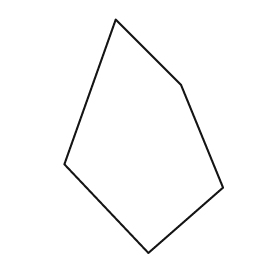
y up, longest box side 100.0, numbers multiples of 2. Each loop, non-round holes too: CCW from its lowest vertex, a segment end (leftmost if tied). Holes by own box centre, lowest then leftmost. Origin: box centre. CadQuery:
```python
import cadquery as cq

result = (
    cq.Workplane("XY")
    .moveTo(2.0, -50.0)
    .lineTo(34.0, -22.0)
    .lineTo(16.0, 22.0)
    .lineTo(-12.0, 50.0)
    .lineTo(-34.0, -12.0)
    .close()
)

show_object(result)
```